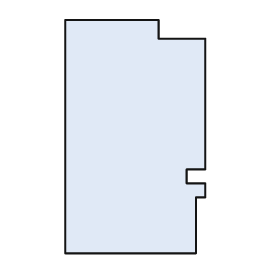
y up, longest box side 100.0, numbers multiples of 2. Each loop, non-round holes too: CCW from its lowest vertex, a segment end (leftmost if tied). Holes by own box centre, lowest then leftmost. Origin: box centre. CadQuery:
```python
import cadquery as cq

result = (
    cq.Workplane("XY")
    .moveTo(-30.0, -50.0)
    .lineTo(26.0, -50.0)
    .lineTo(26.0, -26.0)
    .lineTo(30.0, -26.0)
    .lineTo(30.0, -20.0)
    .lineTo(22.0, -20.0)
    .lineTo(22.0, -14.0)
    .lineTo(30.0, -14.0)
    .lineTo(30.0, 42.0)
    .lineTo(10.0, 42.0)
    .lineTo(10.0, 50.0)
    .lineTo(-30.0, 50.0)
    .close()
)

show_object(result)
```